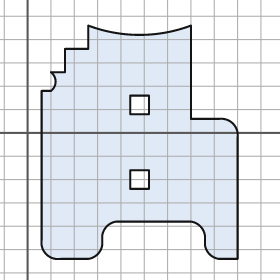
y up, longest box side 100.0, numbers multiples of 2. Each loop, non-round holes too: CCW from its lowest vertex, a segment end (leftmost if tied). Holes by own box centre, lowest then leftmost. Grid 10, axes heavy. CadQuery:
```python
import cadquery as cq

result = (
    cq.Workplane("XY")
    .moveTo(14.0, -54.0)
    .lineTo(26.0, -54.0)
    .threePointArc((30.0, -52.0), (32.0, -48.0))
    .lineTo(32.0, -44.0)
    .threePointArc((34.0, -40.0), (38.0, -38.0))
    .lineTo(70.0, -38.0)
    .threePointArc((74.0, -40.0), (76.0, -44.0))
    .lineTo(76.0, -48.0)
    .threePointArc((78.0, -52.0), (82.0, -54.0))
    .lineTo(90.0, -54.0)
    .lineTo(90.0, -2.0)
    .threePointArc((88.0, 4.0), (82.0, 6.0))
    .lineTo(70.0, 6.0)
    .lineTo(70.0, 46.0)
    .threePointArc((48.0, 42.0), (26.0, 46.0))
    .lineTo(26.0, 36.0)
    .lineTo(16.0, 36.0)
    .lineTo(16.0, 26.0)
    .lineTo(10.0, 26.0)
    .threePointArc((12.0, 22.0), (10.0, 18.0))
    .lineTo(6.0, 18.0)
    .lineTo(6.0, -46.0)
    .threePointArc((8.0, -52.0), (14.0, -54.0))
    .close()
    .moveTo(44.0, -24.0)
    .lineTo(52.0, -24.0)
    .lineTo(52.0, -16.0)
    .lineTo(44.0, -16.0)
    .close()
    .moveTo(44.0, 8.0)
    .lineTo(52.0, 8.0)
    .lineTo(52.0, 16.0)
    .lineTo(44.0, 16.0)
    .close()
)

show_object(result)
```